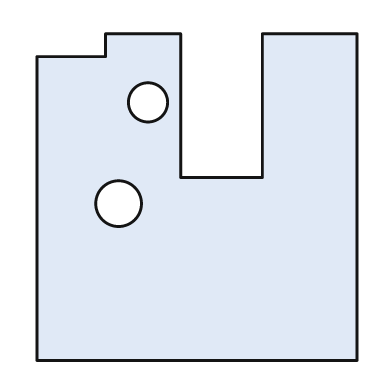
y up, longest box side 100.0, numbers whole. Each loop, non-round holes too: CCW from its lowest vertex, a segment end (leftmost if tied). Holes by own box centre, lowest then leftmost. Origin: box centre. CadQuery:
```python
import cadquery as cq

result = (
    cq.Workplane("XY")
    .moveTo(-49.0, -50.0)
    .lineTo(49.0, -50.0)
    .lineTo(49.0, 50.0)
    .lineTo(20.0, 50.0)
    .lineTo(20.0, 6.0)
    .lineTo(-5.0, 6.0)
    .lineTo(-5.0, 50.0)
    .lineTo(-28.0, 50.0)
    .lineTo(-28.0, 43.0)
    .lineTo(-49.0, 43.0)
    .close()
    .moveTo(-24.0, -2.0)
    .circle(7.0)
    .moveTo(-15.0, 29.0)
    .circle(6.0)
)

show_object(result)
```